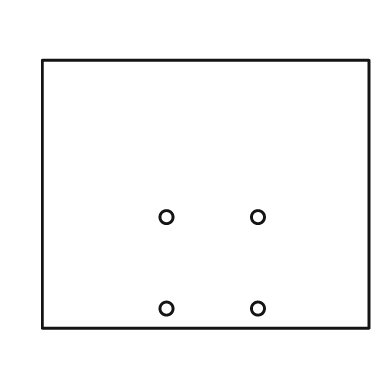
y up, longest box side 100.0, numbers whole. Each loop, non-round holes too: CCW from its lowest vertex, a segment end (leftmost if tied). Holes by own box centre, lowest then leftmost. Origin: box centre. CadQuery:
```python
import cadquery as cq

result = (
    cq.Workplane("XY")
    .moveTo(-50.0, -41.0)
    .lineTo(50.0, -41.0)
    .lineTo(50.0, 41.0)
    .lineTo(-50.0, 41.0)
    .close()
    .moveTo(-12.0, -35.0)
    .circle(2.0)
    .moveTo(16.0, -35.0)
    .circle(2.0)
    .moveTo(-12.0, -7.0)
    .circle(2.0)
    .moveTo(16.0, -7.0)
    .circle(2.0)
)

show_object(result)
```